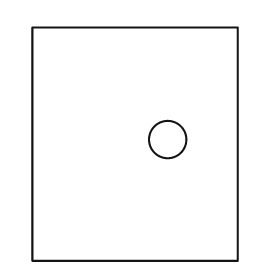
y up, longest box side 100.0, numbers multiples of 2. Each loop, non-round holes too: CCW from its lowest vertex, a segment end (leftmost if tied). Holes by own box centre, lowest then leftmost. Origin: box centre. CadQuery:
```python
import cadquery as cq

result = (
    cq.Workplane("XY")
    .moveTo(-44.0, -50.0)
    .lineTo(44.0, -50.0)
    .lineTo(44.0, 50.0)
    .lineTo(-44.0, 50.0)
    .close()
    .moveTo(14.0, 2.0)
    .circle(8.0)
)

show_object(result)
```